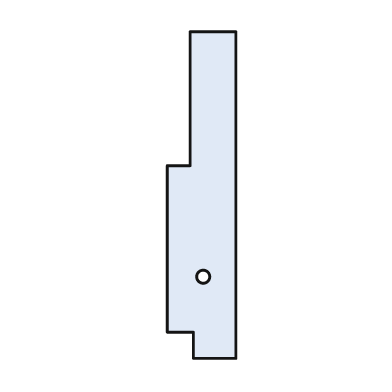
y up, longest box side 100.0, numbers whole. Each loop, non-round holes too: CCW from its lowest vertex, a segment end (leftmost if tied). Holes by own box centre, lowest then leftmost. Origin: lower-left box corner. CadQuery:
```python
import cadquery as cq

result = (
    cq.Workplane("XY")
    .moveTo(8.0, 0.0)
    .lineTo(21.0, 0.0)
    .lineTo(21.0, 100.0)
    .lineTo(7.0, 100.0)
    .lineTo(7.0, 59.0)
    .lineTo(0.0, 59.0)
    .lineTo(0.0, 8.0)
    .lineTo(8.0, 8.0)
    .close()
    .moveTo(11.0, 25.0)
    .circle(2.0)
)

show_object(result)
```